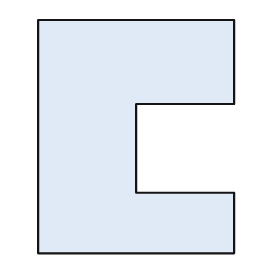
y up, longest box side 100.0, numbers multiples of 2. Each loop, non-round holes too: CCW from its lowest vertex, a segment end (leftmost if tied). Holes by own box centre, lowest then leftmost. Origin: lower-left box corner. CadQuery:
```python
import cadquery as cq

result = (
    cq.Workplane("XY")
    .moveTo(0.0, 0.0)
    .lineTo(84.0, 0.0)
    .lineTo(84.0, 26.0)
    .lineTo(42.0, 26.0)
    .lineTo(42.0, 64.0)
    .lineTo(84.0, 64.0)
    .lineTo(84.0, 100.0)
    .lineTo(0.0, 100.0)
    .close()
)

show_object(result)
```